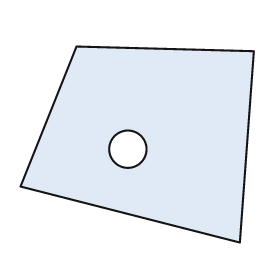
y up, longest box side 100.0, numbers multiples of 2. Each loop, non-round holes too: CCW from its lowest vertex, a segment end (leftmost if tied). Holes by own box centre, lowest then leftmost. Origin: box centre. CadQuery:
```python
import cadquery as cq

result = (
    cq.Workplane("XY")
    .moveTo(44.0, -42.0)
    .lineTo(50.0, 40.0)
    .lineTo(-26.0, 42.0)
    .lineTo(-50.0, -18.0)
    .close()
    .moveTo(-4.0, -2.0)
    .circle(8.0)
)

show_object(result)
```